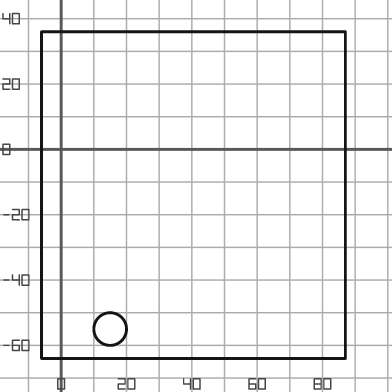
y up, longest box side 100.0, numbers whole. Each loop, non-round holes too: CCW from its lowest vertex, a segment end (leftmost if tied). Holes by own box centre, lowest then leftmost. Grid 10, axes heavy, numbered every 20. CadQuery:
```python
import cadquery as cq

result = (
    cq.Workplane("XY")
    .moveTo(-6.0, -64.0)
    .lineTo(87.0, -64.0)
    .lineTo(87.0, 36.0)
    .lineTo(-6.0, 36.0)
    .close()
    .moveTo(15.0, -55.0)
    .circle(5.0)
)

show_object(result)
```